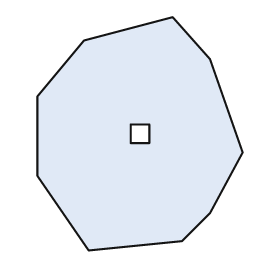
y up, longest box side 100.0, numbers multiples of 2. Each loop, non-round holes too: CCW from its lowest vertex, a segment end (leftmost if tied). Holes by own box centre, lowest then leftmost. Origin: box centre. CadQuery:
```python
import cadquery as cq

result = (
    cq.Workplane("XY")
    .moveTo(-22.0, -50.0)
    .lineTo(18.0, -46.0)
    .lineTo(30.0, -34.0)
    .lineTo(44.0, -8.0)
    .lineTo(30.0, 32.0)
    .lineTo(14.0, 50.0)
    .lineTo(-24.0, 40.0)
    .lineTo(-44.0, 16.0)
    .lineTo(-44.0, -18.0)
    .close()
    .moveTo(-4.0, -4.0)
    .lineTo(4.0, -4.0)
    .lineTo(4.0, 4.0)
    .lineTo(-4.0, 4.0)
    .close()
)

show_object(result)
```